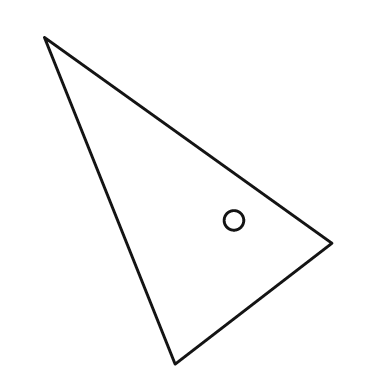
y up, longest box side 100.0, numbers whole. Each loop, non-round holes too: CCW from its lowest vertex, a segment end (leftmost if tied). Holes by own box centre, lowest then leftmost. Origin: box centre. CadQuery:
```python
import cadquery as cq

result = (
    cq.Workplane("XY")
    .moveTo(-4.0, -50.0)
    .lineTo(44.0, -13.0)
    .lineTo(-44.0, 50.0)
    .close()
    .moveTo(14.0, -6.0)
    .circle(3.0)
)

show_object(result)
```